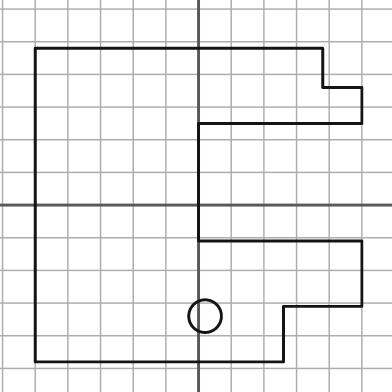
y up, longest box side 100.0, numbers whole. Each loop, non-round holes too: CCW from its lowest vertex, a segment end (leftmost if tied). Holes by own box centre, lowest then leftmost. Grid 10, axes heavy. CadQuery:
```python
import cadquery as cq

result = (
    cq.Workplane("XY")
    .moveTo(-50.0, -48.0)
    .lineTo(26.0, -48.0)
    .lineTo(26.0, -31.0)
    .lineTo(50.0, -31.0)
    .lineTo(50.0, -11.0)
    .lineTo(0.0, -11.0)
    .lineTo(0.0, 25.0)
    .lineTo(50.0, 25.0)
    .lineTo(50.0, 36.0)
    .lineTo(38.0, 36.0)
    .lineTo(38.0, 48.0)
    .lineTo(-50.0, 48.0)
    .close()
    .moveTo(2.0, -34.0)
    .circle(5.0)
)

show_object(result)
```